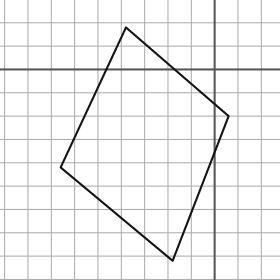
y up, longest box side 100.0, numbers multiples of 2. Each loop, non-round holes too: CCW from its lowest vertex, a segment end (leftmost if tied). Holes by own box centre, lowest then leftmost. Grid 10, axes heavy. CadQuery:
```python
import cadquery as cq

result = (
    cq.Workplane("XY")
    .moveTo(-18.0, -82.0)
    .lineTo(6.0, -20.0)
    .lineTo(-38.0, 18.0)
    .lineTo(-66.0, -42.0)
    .close()
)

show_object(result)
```